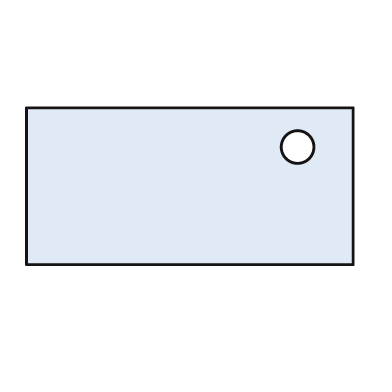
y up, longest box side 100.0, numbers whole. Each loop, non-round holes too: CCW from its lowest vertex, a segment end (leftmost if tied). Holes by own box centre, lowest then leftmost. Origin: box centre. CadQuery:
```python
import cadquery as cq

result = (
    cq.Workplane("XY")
    .moveTo(-50.0, -24.0)
    .lineTo(50.0, -24.0)
    .lineTo(50.0, 24.0)
    .lineTo(-50.0, 24.0)
    .close()
    .moveTo(33.0, 12.0)
    .circle(5.0)
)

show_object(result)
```